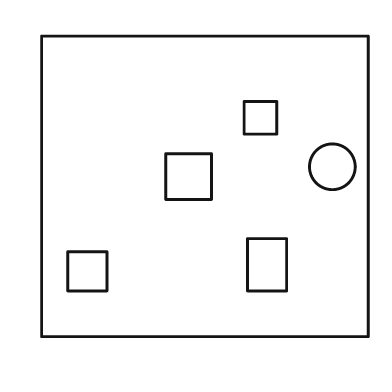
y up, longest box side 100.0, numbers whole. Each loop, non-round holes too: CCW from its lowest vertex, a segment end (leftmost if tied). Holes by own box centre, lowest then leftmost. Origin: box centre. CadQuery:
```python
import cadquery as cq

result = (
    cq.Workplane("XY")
    .moveTo(-50.0, -46.0)
    .lineTo(50.0, -46.0)
    .lineTo(50.0, 46.0)
    .lineTo(-50.0, 46.0)
    .close()
    .moveTo(-42.0, -32.0)
    .lineTo(-30.0, -32.0)
    .lineTo(-30.0, -20.0)
    .lineTo(-42.0, -20.0)
    .close()
    .moveTo(13.0, -32.0)
    .lineTo(25.0, -32.0)
    .lineTo(25.0, -16.0)
    .lineTo(13.0, -16.0)
    .close()
    .moveTo(-12.0, -4.0)
    .lineTo(2.0, -4.0)
    .lineTo(2.0, 10.0)
    .lineTo(-12.0, 10.0)
    .close()
    .moveTo(39.0, 6.0)
    .circle(7.0)
    .moveTo(12.0, 16.0)
    .lineTo(22.0, 16.0)
    .lineTo(22.0, 26.0)
    .lineTo(12.0, 26.0)
    .close()
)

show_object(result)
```